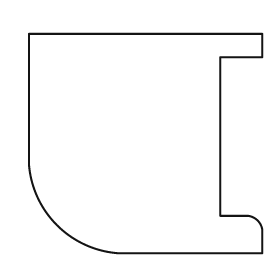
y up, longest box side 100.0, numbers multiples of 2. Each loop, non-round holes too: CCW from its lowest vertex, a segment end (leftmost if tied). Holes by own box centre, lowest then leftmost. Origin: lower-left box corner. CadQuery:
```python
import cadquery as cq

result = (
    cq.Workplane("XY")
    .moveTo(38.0, 0.0)
    .lineTo(100.0, 0.0)
    .lineTo(100.0, 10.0)
    .threePointArc((98.0, 14.0), (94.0, 16.0))
    .lineTo(82.0, 16.0)
    .lineTo(82.0, 84.0)
    .lineTo(100.0, 84.0)
    .lineTo(100.0, 94.0)
    .lineTo(0.0, 94.0)
    .lineTo(0.0, 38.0)
    .threePointArc((12.0, 12.0), (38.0, 0.0))
    .close()
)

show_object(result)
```